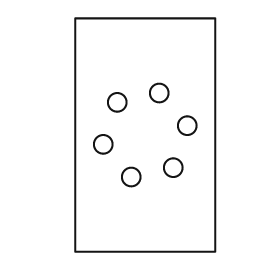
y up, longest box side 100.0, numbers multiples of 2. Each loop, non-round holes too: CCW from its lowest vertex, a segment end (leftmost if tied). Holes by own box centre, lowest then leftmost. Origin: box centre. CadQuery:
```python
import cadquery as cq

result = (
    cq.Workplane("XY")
    .moveTo(-30.0, -50.0)
    .lineTo(30.0, -50.0)
    .lineTo(30.0, 50.0)
    .lineTo(-30.0, 50.0)
    .close()
    .moveTo(-6.0, -18.0)
    .circle(4.0)
    .moveTo(12.0, -14.0)
    .circle(4.0)
    .moveTo(-18.0, -4.0)
    .circle(4.0)
    .moveTo(18.0, 4.0)
    .circle(4.0)
    .moveTo(-12.0, 14.0)
    .circle(4.0)
    .moveTo(6.0, 18.0)
    .circle(4.0)
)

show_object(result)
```